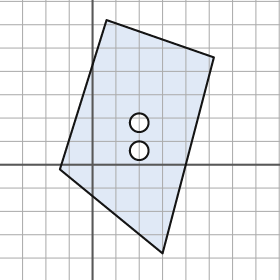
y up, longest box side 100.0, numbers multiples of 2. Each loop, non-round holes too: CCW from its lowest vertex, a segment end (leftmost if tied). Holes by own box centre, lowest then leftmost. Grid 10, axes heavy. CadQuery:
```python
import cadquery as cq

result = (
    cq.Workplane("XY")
    .moveTo(30.0, -38.0)
    .lineTo(52.0, 46.0)
    .lineTo(6.0, 62.0)
    .lineTo(-14.0, -2.0)
    .close()
    .moveTo(20.0, 6.0)
    .circle(4.0)
    .moveTo(20.0, 18.0)
    .circle(4.0)
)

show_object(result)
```